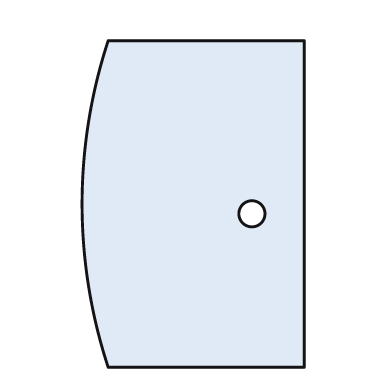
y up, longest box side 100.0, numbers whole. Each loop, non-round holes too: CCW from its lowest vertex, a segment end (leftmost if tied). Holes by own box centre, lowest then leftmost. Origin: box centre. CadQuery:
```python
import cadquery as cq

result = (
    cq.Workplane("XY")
    .moveTo(-26.0, -50.0)
    .lineTo(34.0, -50.0)
    .lineTo(34.0, 50.0)
    .lineTo(-26.0, 50.0)
    .threePointArc((-34.0, 0.0), (-26.0, -50.0))
    .close()
    .moveTo(18.0, -3.0)
    .circle(4.0)
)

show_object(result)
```